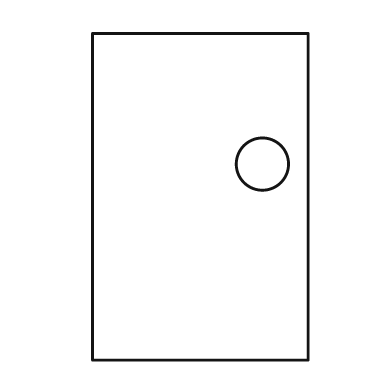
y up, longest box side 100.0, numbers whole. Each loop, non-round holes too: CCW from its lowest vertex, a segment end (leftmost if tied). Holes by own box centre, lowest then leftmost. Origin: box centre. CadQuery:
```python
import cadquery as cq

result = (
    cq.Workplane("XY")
    .moveTo(-33.0, -50.0)
    .lineTo(33.0, -50.0)
    .lineTo(33.0, 50.0)
    .lineTo(-33.0, 50.0)
    .close()
    .moveTo(19.0, 10.0)
    .circle(8.0)
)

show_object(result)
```